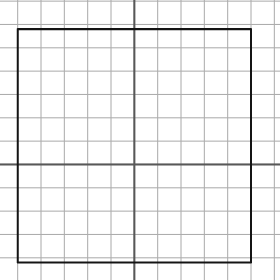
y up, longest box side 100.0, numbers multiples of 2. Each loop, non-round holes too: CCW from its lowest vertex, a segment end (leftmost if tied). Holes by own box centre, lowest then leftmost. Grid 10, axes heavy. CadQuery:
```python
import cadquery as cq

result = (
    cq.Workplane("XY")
    .moveTo(-50.0, -42.0)
    .lineTo(50.0, -42.0)
    .lineTo(50.0, 58.0)
    .lineTo(-50.0, 58.0)
    .close()
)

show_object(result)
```